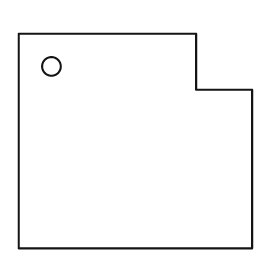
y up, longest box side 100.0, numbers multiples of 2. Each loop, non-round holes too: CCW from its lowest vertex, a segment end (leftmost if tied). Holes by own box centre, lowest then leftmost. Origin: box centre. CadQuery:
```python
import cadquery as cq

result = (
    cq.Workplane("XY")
    .moveTo(-50.0, -46.0)
    .lineTo(50.0, -46.0)
    .lineTo(50.0, 22.0)
    .lineTo(26.0, 22.0)
    .lineTo(26.0, 46.0)
    .lineTo(-50.0, 46.0)
    .close()
    .moveTo(-36.0, 32.0)
    .circle(4.0)
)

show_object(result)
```